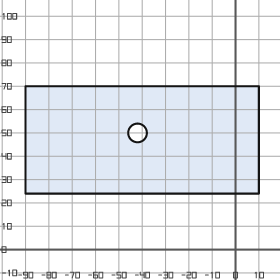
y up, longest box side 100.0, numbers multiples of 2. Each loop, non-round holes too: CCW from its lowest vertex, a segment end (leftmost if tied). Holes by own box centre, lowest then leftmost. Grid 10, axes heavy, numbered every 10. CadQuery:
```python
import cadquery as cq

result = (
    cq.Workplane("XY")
    .moveTo(-90.0, 24.0)
    .lineTo(10.0, 24.0)
    .lineTo(10.0, 70.0)
    .lineTo(-90.0, 70.0)
    .close()
    .moveTo(-42.0, 50.0)
    .circle(4.0)
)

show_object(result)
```